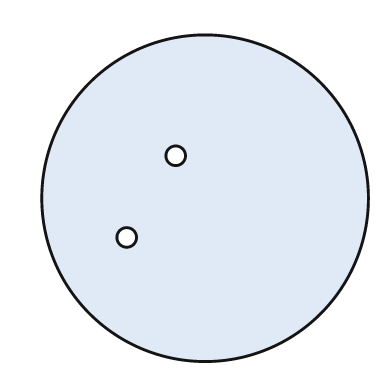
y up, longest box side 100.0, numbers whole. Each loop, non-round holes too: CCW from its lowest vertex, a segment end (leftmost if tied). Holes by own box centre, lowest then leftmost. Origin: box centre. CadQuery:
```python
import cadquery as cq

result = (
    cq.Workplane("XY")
    .moveTo(0.0, 0.0)
    .circle(50.0)
    .moveTo(-24.0, -12.0)
    .circle(3.0)
    .moveTo(-9.0, 13.0)
    .circle(3.0)
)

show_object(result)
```